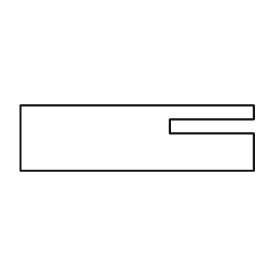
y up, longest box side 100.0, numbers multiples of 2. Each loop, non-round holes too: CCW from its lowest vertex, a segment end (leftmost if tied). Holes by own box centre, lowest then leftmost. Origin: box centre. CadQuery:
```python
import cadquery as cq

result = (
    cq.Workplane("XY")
    .moveTo(-50.0, -14.0)
    .lineTo(50.0, -14.0)
    .lineTo(50.0, 2.0)
    .lineTo(14.0, 2.0)
    .lineTo(14.0, 8.0)
    .lineTo(50.0, 8.0)
    .lineTo(50.0, 14.0)
    .lineTo(-50.0, 14.0)
    .close()
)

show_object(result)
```